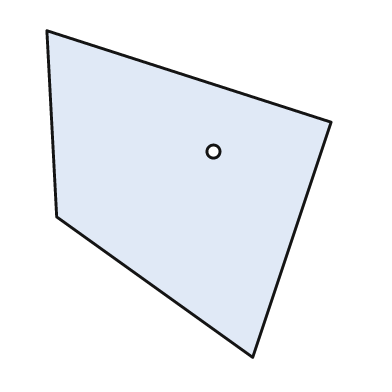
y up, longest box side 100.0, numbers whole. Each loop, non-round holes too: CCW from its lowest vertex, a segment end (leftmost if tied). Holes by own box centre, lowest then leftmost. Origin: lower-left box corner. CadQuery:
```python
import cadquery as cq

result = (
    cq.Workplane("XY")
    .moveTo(63.0, 0.0)
    .lineTo(87.0, 72.0)
    .lineTo(0.0, 100.0)
    .lineTo(3.0, 43.0)
    .close()
    .moveTo(51.0, 63.0)
    .circle(2.0)
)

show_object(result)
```